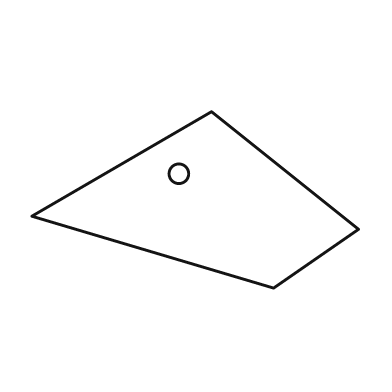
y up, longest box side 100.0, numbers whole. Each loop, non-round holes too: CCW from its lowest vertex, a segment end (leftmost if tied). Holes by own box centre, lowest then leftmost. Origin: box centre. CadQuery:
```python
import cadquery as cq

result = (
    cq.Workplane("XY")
    .moveTo(24.0, -27.0)
    .lineTo(50.0, -9.0)
    .lineTo(5.0, 27.0)
    .lineTo(-50.0, -5.0)
    .close()
    .moveTo(-5.0, 8.0)
    .circle(3.0)
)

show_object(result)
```